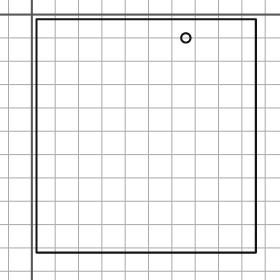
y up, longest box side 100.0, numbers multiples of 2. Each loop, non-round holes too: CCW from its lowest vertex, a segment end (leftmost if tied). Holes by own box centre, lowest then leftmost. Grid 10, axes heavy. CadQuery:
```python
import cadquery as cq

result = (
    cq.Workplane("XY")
    .moveTo(2.0, -102.0)
    .lineTo(96.0, -102.0)
    .lineTo(96.0, -2.0)
    .lineTo(2.0, -2.0)
    .close()
    .moveTo(66.0, -10.0)
    .circle(2.0)
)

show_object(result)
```